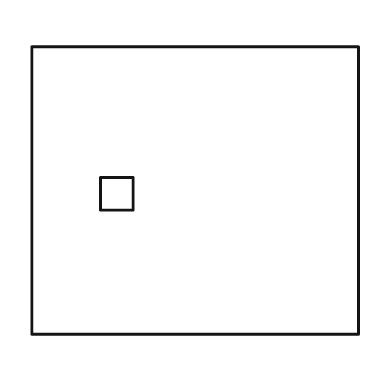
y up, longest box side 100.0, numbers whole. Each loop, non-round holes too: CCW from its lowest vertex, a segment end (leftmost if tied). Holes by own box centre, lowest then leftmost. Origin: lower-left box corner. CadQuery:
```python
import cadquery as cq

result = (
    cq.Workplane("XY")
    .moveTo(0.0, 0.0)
    .lineTo(100.0, 0.0)
    .lineTo(100.0, 88.0)
    .lineTo(0.0, 88.0)
    .close()
    .moveTo(21.0, 38.0)
    .lineTo(31.0, 38.0)
    .lineTo(31.0, 48.0)
    .lineTo(21.0, 48.0)
    .close()
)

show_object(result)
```